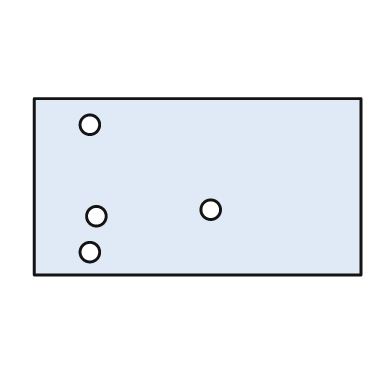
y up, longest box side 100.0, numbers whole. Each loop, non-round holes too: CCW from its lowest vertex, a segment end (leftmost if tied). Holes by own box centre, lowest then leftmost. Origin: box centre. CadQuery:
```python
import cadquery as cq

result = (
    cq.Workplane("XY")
    .moveTo(-50.0, -27.0)
    .lineTo(50.0, -27.0)
    .lineTo(50.0, 27.0)
    .lineTo(-50.0, 27.0)
    .close()
    .moveTo(-33.0, -20.0)
    .circle(3.0)
    .moveTo(-31.0, -9.0)
    .circle(3.0)
    .moveTo(4.0, -7.0)
    .circle(3.0)
    .moveTo(-33.0, 19.0)
    .circle(3.0)
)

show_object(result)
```